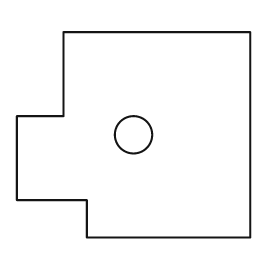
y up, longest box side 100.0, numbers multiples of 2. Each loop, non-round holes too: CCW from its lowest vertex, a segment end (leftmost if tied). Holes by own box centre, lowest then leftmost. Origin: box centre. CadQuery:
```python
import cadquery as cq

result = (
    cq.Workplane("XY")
    .moveTo(-20.0, -44.0)
    .lineTo(50.0, -44.0)
    .lineTo(50.0, 44.0)
    .lineTo(-30.0, 44.0)
    .lineTo(-30.0, 8.0)
    .lineTo(-50.0, 8.0)
    .lineTo(-50.0, -28.0)
    .lineTo(-20.0, -28.0)
    .close()
    .moveTo(0.0, 0.0)
    .circle(8.0)
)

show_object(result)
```